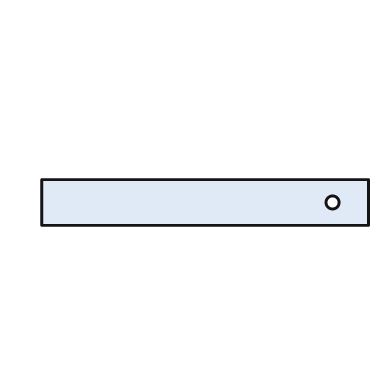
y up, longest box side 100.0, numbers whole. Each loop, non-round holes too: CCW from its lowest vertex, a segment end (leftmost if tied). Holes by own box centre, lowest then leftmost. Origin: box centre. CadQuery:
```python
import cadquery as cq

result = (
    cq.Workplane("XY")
    .moveTo(-50.0, -7.0)
    .lineTo(50.0, -7.0)
    .lineTo(50.0, 7.0)
    .lineTo(-50.0, 7.0)
    .close()
    .moveTo(39.0, 0.0)
    .circle(2.0)
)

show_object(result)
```